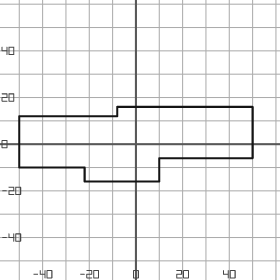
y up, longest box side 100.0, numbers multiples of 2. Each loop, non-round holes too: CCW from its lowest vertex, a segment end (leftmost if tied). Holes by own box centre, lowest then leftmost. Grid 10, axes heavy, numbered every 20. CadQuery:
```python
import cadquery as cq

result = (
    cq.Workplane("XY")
    .moveTo(-22.0, -16.0)
    .lineTo(10.0, -16.0)
    .lineTo(10.0, -6.0)
    .lineTo(50.0, -6.0)
    .lineTo(50.0, 16.0)
    .lineTo(-8.0, 16.0)
    .lineTo(-8.0, 12.0)
    .lineTo(-50.0, 12.0)
    .lineTo(-50.0, -10.0)
    .lineTo(-22.0, -10.0)
    .close()
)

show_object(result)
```